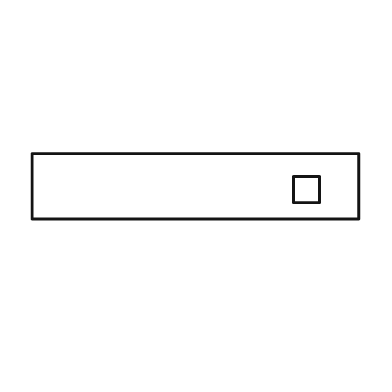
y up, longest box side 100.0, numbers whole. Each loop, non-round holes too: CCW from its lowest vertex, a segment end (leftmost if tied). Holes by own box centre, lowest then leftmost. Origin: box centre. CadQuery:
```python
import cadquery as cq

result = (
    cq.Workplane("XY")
    .moveTo(-50.0, -10.0)
    .lineTo(50.0, -10.0)
    .lineTo(50.0, 10.0)
    .lineTo(-50.0, 10.0)
    .close()
    .moveTo(30.0, -5.0)
    .lineTo(38.0, -5.0)
    .lineTo(38.0, 3.0)
    .lineTo(30.0, 3.0)
    .close()
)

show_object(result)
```